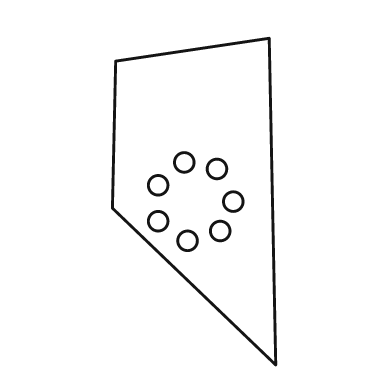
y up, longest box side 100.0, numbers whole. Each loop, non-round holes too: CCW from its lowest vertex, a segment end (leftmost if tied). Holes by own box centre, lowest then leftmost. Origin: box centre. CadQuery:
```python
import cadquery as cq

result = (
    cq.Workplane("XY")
    .moveTo(25.0, -50.0)
    .lineTo(23.0, 50.0)
    .lineTo(-24.0, 43.0)
    .lineTo(-25.0, -2.0)
    .close()
    .moveTo(-2.0, -12.0)
    .circle(3.0)
    .moveTo(8.0, -9.0)
    .circle(3.0)
    .moveTo(-11.0, -6.0)
    .circle(3.0)
    .moveTo(12.0, 0.0)
    .circle(3.0)
    .moveTo(-11.0, 5.0)
    .circle(3.0)
    .moveTo(7.0, 10.0)
    .circle(3.0)
    .moveTo(-3.0, 12.0)
    .circle(3.0)
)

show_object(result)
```